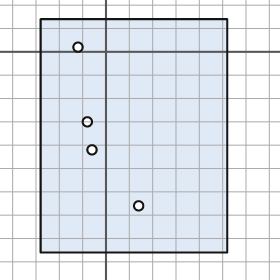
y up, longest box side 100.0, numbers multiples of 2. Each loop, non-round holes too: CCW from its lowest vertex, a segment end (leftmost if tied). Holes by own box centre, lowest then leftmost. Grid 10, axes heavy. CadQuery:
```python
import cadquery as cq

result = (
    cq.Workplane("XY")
    .moveTo(-28.0, -86.0)
    .lineTo(52.0, -86.0)
    .lineTo(52.0, 14.0)
    .lineTo(-28.0, 14.0)
    .close()
    .moveTo(14.0, -66.0)
    .circle(2.0)
    .moveTo(-6.0, -42.0)
    .circle(2.0)
    .moveTo(-8.0, -30.0)
    .circle(2.0)
    .moveTo(-12.0, 2.0)
    .circle(2.0)
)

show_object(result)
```